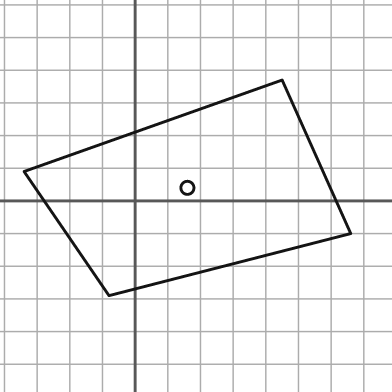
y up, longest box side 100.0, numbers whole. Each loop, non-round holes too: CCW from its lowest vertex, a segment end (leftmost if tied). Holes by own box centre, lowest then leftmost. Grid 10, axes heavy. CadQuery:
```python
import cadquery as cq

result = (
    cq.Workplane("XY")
    .moveTo(-8.0, -29.0)
    .lineTo(66.0, -10.0)
    .lineTo(45.0, 37.0)
    .lineTo(-34.0, 9.0)
    .close()
    .moveTo(16.0, 4.0)
    .circle(2.0)
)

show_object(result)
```